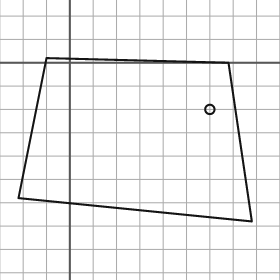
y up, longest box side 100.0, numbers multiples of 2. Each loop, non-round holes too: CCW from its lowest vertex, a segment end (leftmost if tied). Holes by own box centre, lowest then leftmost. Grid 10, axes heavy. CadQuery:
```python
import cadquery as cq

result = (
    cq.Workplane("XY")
    .moveTo(78.0, -68.0)
    .lineTo(68.0, 0.0)
    .lineTo(-10.0, 2.0)
    .lineTo(-22.0, -58.0)
    .close()
    .moveTo(60.0, -20.0)
    .circle(2.0)
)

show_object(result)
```